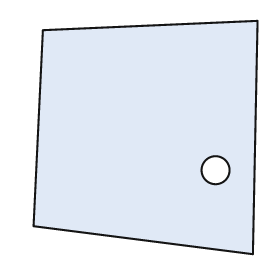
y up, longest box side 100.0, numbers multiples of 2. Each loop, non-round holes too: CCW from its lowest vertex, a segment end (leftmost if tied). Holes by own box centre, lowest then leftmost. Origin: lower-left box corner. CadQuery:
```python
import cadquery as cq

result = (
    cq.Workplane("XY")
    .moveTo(94.0, 0.0)
    .lineTo(96.0, 100.0)
    .lineTo(4.0, 96.0)
    .lineTo(0.0, 12.0)
    .close()
    .moveTo(78.0, 36.0)
    .circle(6.0)
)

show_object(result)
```